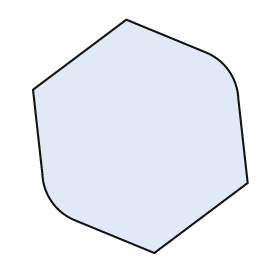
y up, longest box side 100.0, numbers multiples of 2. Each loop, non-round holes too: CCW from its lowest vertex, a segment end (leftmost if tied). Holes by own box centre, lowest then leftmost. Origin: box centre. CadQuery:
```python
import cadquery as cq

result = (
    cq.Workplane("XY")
    .moveTo(6.0, -50.0)
    .lineTo(46.0, -20.0)
    .lineTo(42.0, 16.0)
    .threePointArc((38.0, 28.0), (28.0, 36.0))
    .lineTo(-6.0, 50.0)
    .lineTo(-46.0, 20.0)
    .lineTo(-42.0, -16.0)
    .threePointArc((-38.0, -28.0), (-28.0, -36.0))
    .close()
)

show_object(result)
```